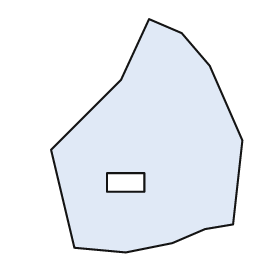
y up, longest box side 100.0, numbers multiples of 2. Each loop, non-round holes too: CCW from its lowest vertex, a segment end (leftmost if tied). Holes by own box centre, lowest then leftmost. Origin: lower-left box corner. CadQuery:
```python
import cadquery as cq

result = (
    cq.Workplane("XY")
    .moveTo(32.0, 0.0)
    .lineTo(52.0, 4.0)
    .lineTo(66.0, 10.0)
    .lineTo(78.0, 12.0)
    .lineTo(82.0, 48.0)
    .lineTo(68.0, 80.0)
    .lineTo(56.0, 94.0)
    .lineTo(42.0, 100.0)
    .lineTo(30.0, 74.0)
    .lineTo(0.0, 44.0)
    .lineTo(10.0, 2.0)
    .close()
    .moveTo(24.0, 26.0)
    .lineTo(40.0, 26.0)
    .lineTo(40.0, 34.0)
    .lineTo(24.0, 34.0)
    .close()
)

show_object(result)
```